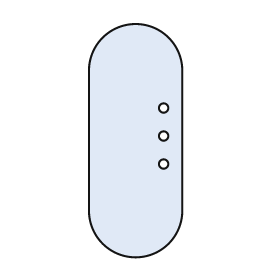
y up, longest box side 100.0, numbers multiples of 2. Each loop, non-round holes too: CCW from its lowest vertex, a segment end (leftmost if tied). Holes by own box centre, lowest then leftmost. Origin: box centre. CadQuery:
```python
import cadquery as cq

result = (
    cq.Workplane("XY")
    .moveTo(-20.0, -30.0)
    .threePointArc((0.0, -50.0), (20.0, -30.0))
    .lineTo(20.0, 30.0)
    .threePointArc((0.0, 50.0), (-20.0, 30.0))
    .close()
    .moveTo(12.0, -10.0)
    .circle(2.0)
    .moveTo(12.0, 2.0)
    .circle(2.0)
    .moveTo(12.0, 14.0)
    .circle(2.0)
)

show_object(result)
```